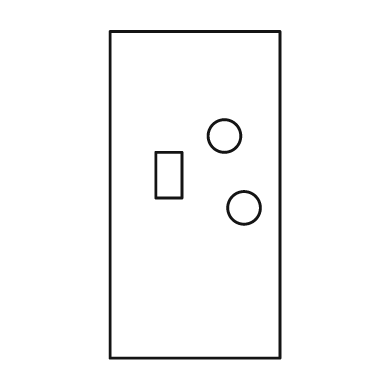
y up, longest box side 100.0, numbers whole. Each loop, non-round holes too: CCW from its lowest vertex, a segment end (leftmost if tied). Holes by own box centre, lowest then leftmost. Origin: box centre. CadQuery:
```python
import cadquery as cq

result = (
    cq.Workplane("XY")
    .moveTo(-26.0, -50.0)
    .lineTo(26.0, -50.0)
    .lineTo(26.0, 50.0)
    .lineTo(-26.0, 50.0)
    .close()
    .moveTo(15.0, -4.0)
    .circle(5.0)
    .moveTo(-12.0, -1.0)
    .lineTo(-4.0, -1.0)
    .lineTo(-4.0, 13.0)
    .lineTo(-12.0, 13.0)
    .close()
    .moveTo(9.0, 18.0)
    .circle(5.0)
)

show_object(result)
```